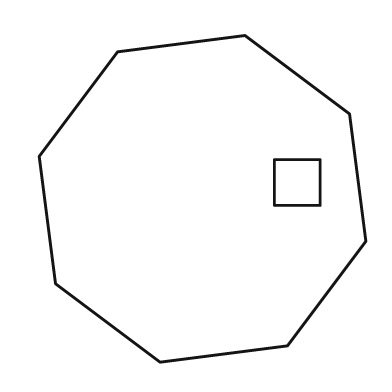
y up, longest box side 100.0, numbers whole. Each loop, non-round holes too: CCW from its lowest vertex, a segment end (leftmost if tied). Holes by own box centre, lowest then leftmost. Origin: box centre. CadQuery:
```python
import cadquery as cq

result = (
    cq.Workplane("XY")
    .moveTo(-13.0, -50.0)
    .lineTo(26.0, -45.0)
    .lineTo(50.0, -13.0)
    .lineTo(45.0, 26.0)
    .lineTo(13.0, 50.0)
    .lineTo(-26.0, 45.0)
    .lineTo(-50.0, 13.0)
    .lineTo(-45.0, -26.0)
    .close()
    .moveTo(22.0, -2.0)
    .lineTo(36.0, -2.0)
    .lineTo(36.0, 12.0)
    .lineTo(22.0, 12.0)
    .close()
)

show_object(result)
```